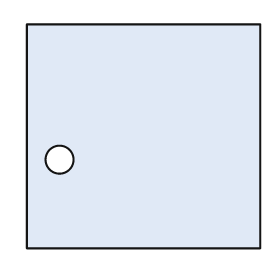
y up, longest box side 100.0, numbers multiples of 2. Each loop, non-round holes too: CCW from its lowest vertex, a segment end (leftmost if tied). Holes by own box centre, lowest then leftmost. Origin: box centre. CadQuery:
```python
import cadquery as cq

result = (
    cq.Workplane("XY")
    .moveTo(-50.0, -48.0)
    .lineTo(50.0, -48.0)
    .lineTo(50.0, 48.0)
    .lineTo(-50.0, 48.0)
    .close()
    .moveTo(-36.0, -10.0)
    .circle(6.0)
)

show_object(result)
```